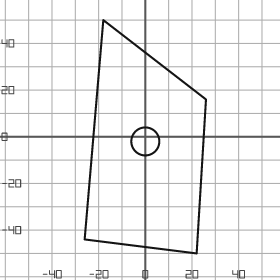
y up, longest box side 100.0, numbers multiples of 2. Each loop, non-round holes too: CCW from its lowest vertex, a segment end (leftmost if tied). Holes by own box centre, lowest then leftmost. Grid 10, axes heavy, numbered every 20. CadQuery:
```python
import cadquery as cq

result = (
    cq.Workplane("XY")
    .moveTo(22.0, -50.0)
    .lineTo(26.0, 16.0)
    .lineTo(-18.0, 50.0)
    .lineTo(-26.0, -44.0)
    .close()
    .moveTo(0.0, -2.0)
    .circle(6.0)
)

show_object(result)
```